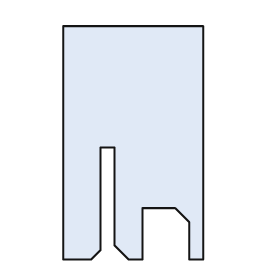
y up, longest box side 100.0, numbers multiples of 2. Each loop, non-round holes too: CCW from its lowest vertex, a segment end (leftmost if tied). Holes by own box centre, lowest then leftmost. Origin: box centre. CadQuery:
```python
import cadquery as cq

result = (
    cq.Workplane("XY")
    .moveTo(-30.0, -50.0)
    .lineTo(-18.0, -50.0)
    .lineTo(-14.0, -46.0)
    .lineTo(-14.0, -2.0)
    .lineTo(-8.0, -2.0)
    .lineTo(-8.0, -44.0)
    .lineTo(-2.0, -50.0)
    .lineTo(4.0, -50.0)
    .lineTo(4.0, -28.0)
    .lineTo(18.0, -28.0)
    .lineTo(24.0, -34.0)
    .lineTo(24.0, -50.0)
    .lineTo(30.0, -50.0)
    .lineTo(30.0, 50.0)
    .lineTo(-30.0, 50.0)
    .close()
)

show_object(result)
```